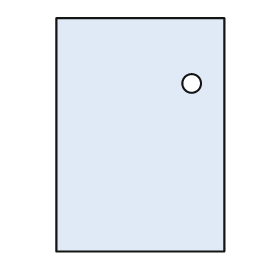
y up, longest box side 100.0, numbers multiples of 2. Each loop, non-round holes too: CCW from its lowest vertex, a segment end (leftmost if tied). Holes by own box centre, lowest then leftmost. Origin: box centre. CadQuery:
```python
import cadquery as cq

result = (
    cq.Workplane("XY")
    .moveTo(-36.0, -50.0)
    .lineTo(36.0, -50.0)
    .lineTo(36.0, 50.0)
    .lineTo(-36.0, 50.0)
    .close()
    .moveTo(22.0, 22.0)
    .circle(4.0)
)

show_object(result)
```